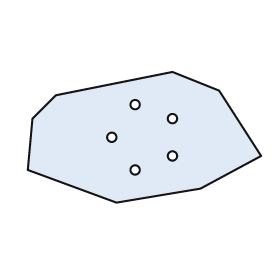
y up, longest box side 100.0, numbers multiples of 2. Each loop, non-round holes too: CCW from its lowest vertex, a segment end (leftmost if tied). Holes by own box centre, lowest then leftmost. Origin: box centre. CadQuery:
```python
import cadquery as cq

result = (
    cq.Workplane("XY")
    .moveTo(-12.0, -28.0)
    .lineTo(24.0, -22.0)
    .lineTo(50.0, -8.0)
    .lineTo(32.0, 20.0)
    .lineTo(12.0, 28.0)
    .lineTo(-38.0, 18.0)
    .lineTo(-48.0, 8.0)
    .lineTo(-50.0, -14.0)
    .close()
    .moveTo(-4.0, -14.0)
    .circle(2.0)
    .moveTo(12.0, -8.0)
    .circle(2.0)
    .moveTo(-14.0, 0.0)
    .circle(2.0)
    .moveTo(12.0, 8.0)
    .circle(2.0)
    .moveTo(-4.0, 14.0)
    .circle(2.0)
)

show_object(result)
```